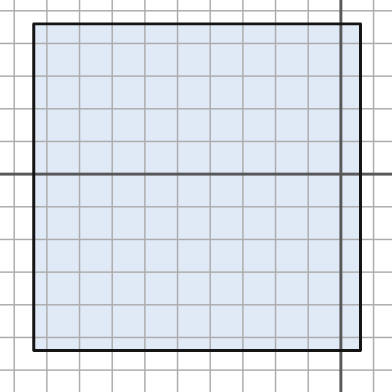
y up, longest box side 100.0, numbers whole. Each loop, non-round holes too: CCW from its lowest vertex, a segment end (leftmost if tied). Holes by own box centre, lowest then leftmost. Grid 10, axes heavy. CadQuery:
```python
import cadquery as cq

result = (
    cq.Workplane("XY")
    .moveTo(-94.0, -54.0)
    .lineTo(6.0, -54.0)
    .lineTo(6.0, 46.0)
    .lineTo(-94.0, 46.0)
    .close()
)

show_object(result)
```